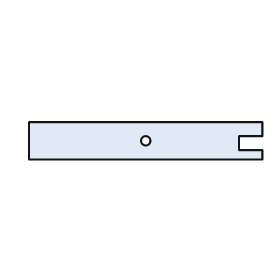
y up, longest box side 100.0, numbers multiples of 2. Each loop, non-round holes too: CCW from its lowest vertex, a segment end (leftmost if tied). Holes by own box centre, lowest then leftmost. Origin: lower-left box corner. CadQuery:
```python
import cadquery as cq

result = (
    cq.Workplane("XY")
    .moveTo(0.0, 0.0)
    .lineTo(100.0, 0.0)
    .lineTo(100.0, 4.0)
    .lineTo(90.0, 4.0)
    .lineTo(90.0, 10.0)
    .lineTo(100.0, 10.0)
    .lineTo(100.0, 16.0)
    .lineTo(0.0, 16.0)
    .close()
    .moveTo(50.0, 8.0)
    .circle(2.0)
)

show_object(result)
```